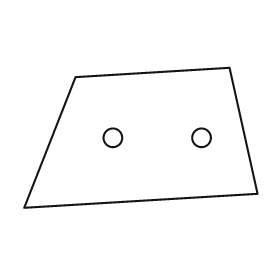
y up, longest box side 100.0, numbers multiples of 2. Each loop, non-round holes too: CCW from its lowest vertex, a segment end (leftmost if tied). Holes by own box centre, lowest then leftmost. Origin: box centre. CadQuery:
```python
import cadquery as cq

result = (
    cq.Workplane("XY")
    .moveTo(-50.0, -30.0)
    .lineTo(50.0, -24.0)
    .lineTo(38.0, 30.0)
    .lineTo(-28.0, 26.0)
    .close()
    .moveTo(-12.0, 0.0)
    .circle(4.0)
    .moveTo(26.0, 0.0)
    .circle(4.0)
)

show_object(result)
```